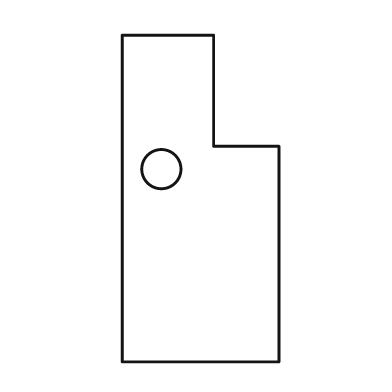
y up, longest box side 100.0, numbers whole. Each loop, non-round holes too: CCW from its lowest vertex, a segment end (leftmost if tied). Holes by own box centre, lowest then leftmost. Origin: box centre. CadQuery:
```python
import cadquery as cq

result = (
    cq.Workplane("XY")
    .moveTo(-24.0, -50.0)
    .lineTo(24.0, -50.0)
    .lineTo(24.0, 16.0)
    .lineTo(4.0, 16.0)
    .lineTo(4.0, 50.0)
    .lineTo(-24.0, 50.0)
    .close()
    .moveTo(-12.0, 9.0)
    .circle(6.0)
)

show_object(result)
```